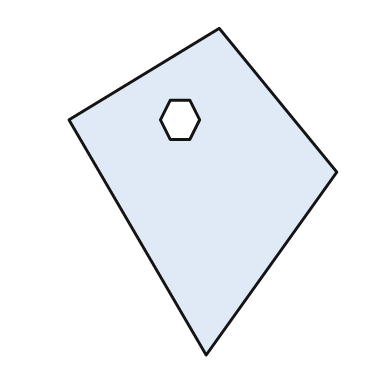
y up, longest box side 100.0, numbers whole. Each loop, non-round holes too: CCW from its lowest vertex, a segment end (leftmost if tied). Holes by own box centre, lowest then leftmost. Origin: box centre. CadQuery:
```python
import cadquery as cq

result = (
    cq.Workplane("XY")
    .moveTo(1.0, -50.0)
    .lineTo(41.0, 6.0)
    .lineTo(5.0, 50.0)
    .lineTo(-41.0, 22.0)
    .close()
    .moveTo(-10.0, 16.0)
    .lineTo(-4.0, 16.0)
    .lineTo(-1.0, 22.0)
    .lineTo(-4.0, 28.0)
    .lineTo(-10.0, 28.0)
    .lineTo(-13.0, 22.0)
    .close()
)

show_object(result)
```